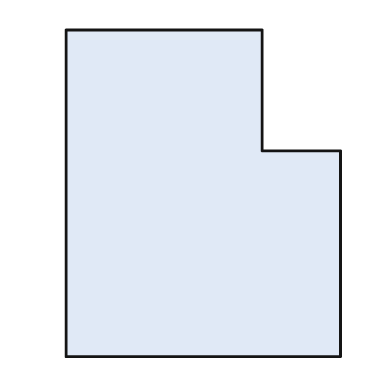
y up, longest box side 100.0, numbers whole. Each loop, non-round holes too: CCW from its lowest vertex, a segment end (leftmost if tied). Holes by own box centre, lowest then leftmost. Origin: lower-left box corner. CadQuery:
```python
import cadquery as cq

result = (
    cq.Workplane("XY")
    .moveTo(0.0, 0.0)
    .lineTo(84.0, 0.0)
    .lineTo(84.0, 63.0)
    .lineTo(60.0, 63.0)
    .lineTo(60.0, 100.0)
    .lineTo(0.0, 100.0)
    .close()
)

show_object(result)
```